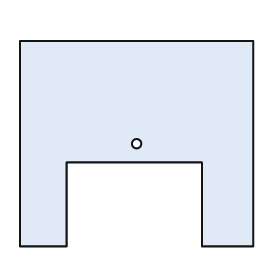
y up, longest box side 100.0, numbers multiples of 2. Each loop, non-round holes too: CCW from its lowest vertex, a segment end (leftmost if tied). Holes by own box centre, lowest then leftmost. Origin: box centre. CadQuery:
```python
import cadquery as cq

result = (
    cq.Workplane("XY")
    .moveTo(-50.0, -44.0)
    .lineTo(-30.0, -44.0)
    .lineTo(-30.0, -8.0)
    .lineTo(28.0, -8.0)
    .lineTo(28.0, -44.0)
    .lineTo(50.0, -44.0)
    .lineTo(50.0, 44.0)
    .lineTo(-50.0, 44.0)
    .close()
    .moveTo(0.0, 0.0)
    .circle(2.0)
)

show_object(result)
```